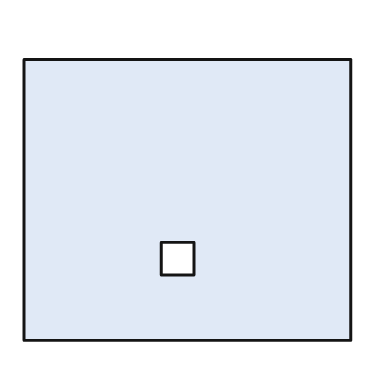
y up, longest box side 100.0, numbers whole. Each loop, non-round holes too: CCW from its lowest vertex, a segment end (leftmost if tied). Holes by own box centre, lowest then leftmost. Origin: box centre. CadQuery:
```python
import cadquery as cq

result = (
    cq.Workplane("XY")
    .moveTo(-50.0, -43.0)
    .lineTo(50.0, -43.0)
    .lineTo(50.0, 43.0)
    .lineTo(-50.0, 43.0)
    .close()
    .moveTo(-8.0, -23.0)
    .lineTo(2.0, -23.0)
    .lineTo(2.0, -13.0)
    .lineTo(-8.0, -13.0)
    .close()
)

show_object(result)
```